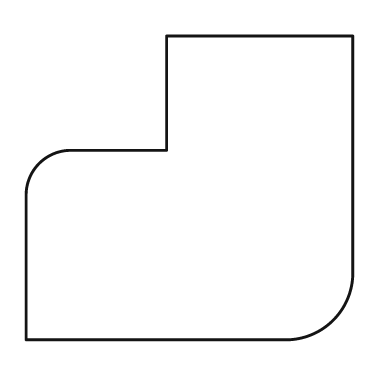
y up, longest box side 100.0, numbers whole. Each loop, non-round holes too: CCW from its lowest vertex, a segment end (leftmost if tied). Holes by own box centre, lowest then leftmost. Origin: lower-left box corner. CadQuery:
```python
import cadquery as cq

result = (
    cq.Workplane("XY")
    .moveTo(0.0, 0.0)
    .lineTo(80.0, 0.0)
    .threePointArc((94.0, 6.0), (100.0, 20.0))
    .lineTo(100.0, 93.0)
    .lineTo(43.0, 93.0)
    .lineTo(43.0, 58.0)
    .lineTo(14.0, 58.0)
    .threePointArc((4.0, 54.0), (0.0, 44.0))
    .close()
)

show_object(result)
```